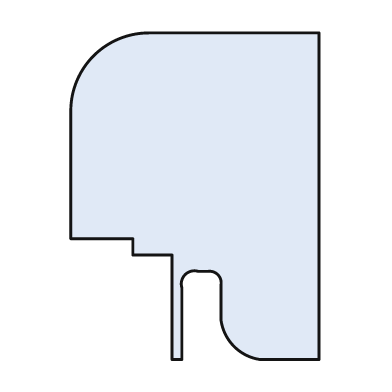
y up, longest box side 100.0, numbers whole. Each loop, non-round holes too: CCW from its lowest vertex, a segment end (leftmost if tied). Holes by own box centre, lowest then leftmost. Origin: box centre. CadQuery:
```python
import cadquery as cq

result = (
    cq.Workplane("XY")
    .moveTo(-7.0, -50.0)
    .lineTo(-4.0, -50.0)
    .lineTo(-4.0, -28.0)
    .threePointArc((-3.0, -24.0), (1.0, -23.0))
    .lineTo(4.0, -23.0)
    .threePointArc((7.0, -24.0), (8.0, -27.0))
    .lineTo(8.0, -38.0)
    .threePointArc((12.0, -46.0), (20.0, -50.0))
    .lineTo(38.0, -50.0)
    .lineTo(38.0, 50.0)
    .lineTo(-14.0, 50.0)
    .threePointArc((-31.0, 43.0), (-38.0, 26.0))
    .lineTo(-38.0, -13.0)
    .lineTo(-19.0, -13.0)
    .lineTo(-19.0, -18.0)
    .lineTo(-7.0, -18.0)
    .close()
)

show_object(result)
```